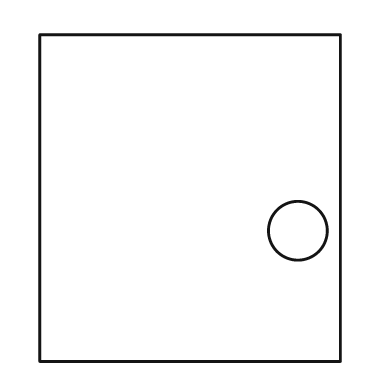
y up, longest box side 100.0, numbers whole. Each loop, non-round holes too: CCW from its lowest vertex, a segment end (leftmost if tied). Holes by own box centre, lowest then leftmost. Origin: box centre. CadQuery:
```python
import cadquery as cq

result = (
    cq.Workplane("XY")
    .moveTo(-46.0, -50.0)
    .lineTo(46.0, -50.0)
    .lineTo(46.0, 50.0)
    .lineTo(-46.0, 50.0)
    .close()
    .moveTo(33.0, -10.0)
    .circle(9.0)
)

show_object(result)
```